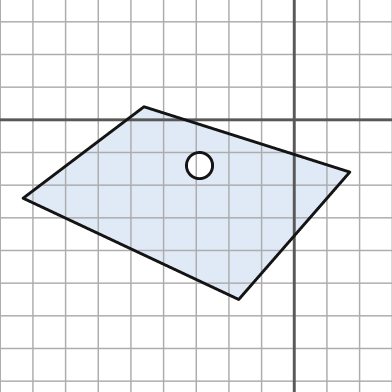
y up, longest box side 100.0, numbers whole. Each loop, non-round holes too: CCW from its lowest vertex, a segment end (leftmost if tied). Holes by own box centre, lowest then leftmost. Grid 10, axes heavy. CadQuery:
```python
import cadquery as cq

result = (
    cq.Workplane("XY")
    .moveTo(-17.0, -55.0)
    .lineTo(17.0, -16.0)
    .lineTo(-46.0, 4.0)
    .lineTo(-83.0, -24.0)
    .close()
    .moveTo(-29.0, -14.0)
    .circle(4.0)
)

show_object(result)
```